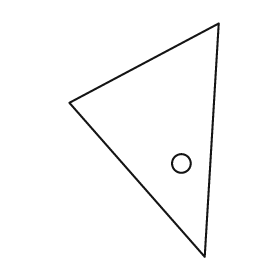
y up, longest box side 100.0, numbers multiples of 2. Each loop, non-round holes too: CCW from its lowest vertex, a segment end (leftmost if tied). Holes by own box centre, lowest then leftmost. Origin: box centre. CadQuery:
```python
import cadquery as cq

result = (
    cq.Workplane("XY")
    .moveTo(26.0, -50.0)
    .lineTo(32.0, 50.0)
    .lineTo(-32.0, 16.0)
    .close()
    .moveTo(16.0, -10.0)
    .circle(4.0)
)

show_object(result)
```